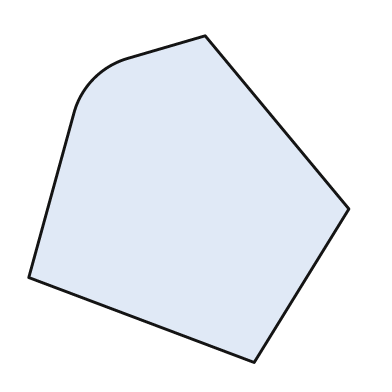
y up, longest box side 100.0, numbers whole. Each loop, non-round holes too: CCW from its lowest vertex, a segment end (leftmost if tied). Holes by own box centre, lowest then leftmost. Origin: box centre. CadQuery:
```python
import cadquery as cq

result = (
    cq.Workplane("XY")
    .moveTo(20.0, -50.0)
    .lineTo(49.0, -3.0)
    .lineTo(5.0, 50.0)
    .lineTo(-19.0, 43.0)
    .threePointArc((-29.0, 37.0), (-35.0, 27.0))
    .lineTo(-49.0, -24.0)
    .close()
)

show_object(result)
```